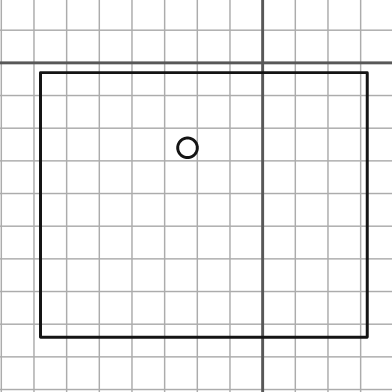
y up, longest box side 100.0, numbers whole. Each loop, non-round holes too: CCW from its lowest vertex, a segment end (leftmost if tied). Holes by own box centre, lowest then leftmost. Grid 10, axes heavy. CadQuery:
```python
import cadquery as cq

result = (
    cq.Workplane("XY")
    .moveTo(-68.0, -84.0)
    .lineTo(32.0, -84.0)
    .lineTo(32.0, -3.0)
    .lineTo(-68.0, -3.0)
    .close()
    .moveTo(-23.0, -26.0)
    .circle(3.0)
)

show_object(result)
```